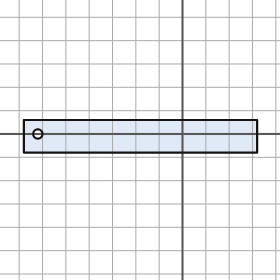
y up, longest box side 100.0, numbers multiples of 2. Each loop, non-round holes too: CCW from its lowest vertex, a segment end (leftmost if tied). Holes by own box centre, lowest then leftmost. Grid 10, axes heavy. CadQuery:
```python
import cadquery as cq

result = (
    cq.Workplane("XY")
    .moveTo(-68.0, -8.0)
    .lineTo(32.0, -8.0)
    .lineTo(32.0, 6.0)
    .lineTo(-68.0, 6.0)
    .close()
    .moveTo(-62.0, 0.0)
    .circle(2.0)
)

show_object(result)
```